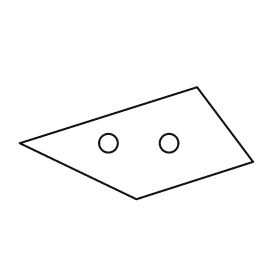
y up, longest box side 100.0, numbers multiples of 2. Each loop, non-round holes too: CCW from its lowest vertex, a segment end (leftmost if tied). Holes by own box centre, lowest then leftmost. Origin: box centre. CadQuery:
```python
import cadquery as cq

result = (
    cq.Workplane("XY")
    .moveTo(0.0, -24.0)
    .lineTo(50.0, -8.0)
    .lineTo(26.0, 24.0)
    .lineTo(-50.0, 0.0)
    .close()
    .moveTo(-12.0, 0.0)
    .circle(4.0)
    .moveTo(14.0, 0.0)
    .circle(4.0)
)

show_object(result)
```